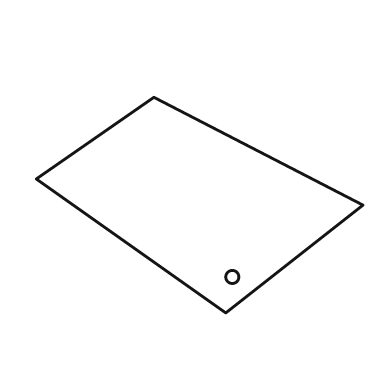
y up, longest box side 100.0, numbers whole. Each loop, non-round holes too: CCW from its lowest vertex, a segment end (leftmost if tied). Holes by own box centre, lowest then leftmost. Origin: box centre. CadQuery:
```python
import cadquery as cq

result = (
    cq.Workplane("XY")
    .moveTo(8.0, -33.0)
    .lineTo(50.0, 0.0)
    .lineTo(-14.0, 33.0)
    .lineTo(-50.0, 8.0)
    .close()
    .moveTo(10.0, -22.0)
    .circle(2.0)
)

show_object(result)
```